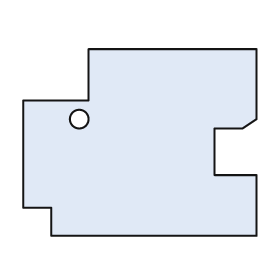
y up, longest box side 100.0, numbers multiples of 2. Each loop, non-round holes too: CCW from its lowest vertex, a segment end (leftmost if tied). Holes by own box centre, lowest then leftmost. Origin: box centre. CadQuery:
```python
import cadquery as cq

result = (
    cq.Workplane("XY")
    .moveTo(-38.0, -40.0)
    .lineTo(50.0, -40.0)
    .lineTo(50.0, -14.0)
    .lineTo(32.0, -14.0)
    .lineTo(32.0, 6.0)
    .lineTo(44.0, 6.0)
    .lineTo(50.0, 10.0)
    .lineTo(50.0, 40.0)
    .lineTo(-22.0, 40.0)
    .lineTo(-22.0, 18.0)
    .lineTo(-50.0, 18.0)
    .lineTo(-50.0, -28.0)
    .lineTo(-38.0, -28.0)
    .close()
    .moveTo(-26.0, 10.0)
    .circle(4.0)
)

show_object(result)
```